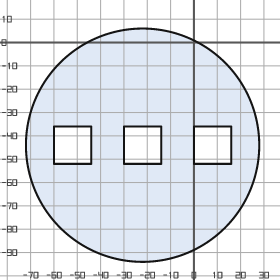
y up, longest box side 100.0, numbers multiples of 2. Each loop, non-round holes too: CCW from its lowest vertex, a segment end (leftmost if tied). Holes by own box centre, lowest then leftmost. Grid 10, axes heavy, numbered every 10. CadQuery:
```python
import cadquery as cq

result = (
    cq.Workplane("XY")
    .moveTo(-22.0, -44.0)
    .circle(50.0)
    .moveTo(-60.0, -52.0)
    .lineTo(-44.0, -52.0)
    .lineTo(-44.0, -36.0)
    .lineTo(-60.0, -36.0)
    .close()
    .moveTo(-30.0, -52.0)
    .lineTo(-14.0, -52.0)
    .lineTo(-14.0, -36.0)
    .lineTo(-30.0, -36.0)
    .close()
    .moveTo(0.0, -52.0)
    .lineTo(16.0, -52.0)
    .lineTo(16.0, -36.0)
    .lineTo(0.0, -36.0)
    .close()
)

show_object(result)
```